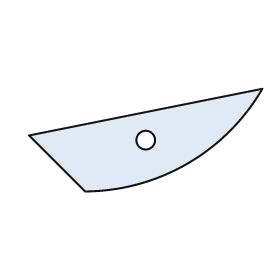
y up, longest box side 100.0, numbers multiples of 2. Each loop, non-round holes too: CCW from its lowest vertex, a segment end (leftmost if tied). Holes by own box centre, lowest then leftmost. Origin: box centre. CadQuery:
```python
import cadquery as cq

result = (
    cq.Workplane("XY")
    .moveTo(-26.0, -22.0)
    .threePointArc((18.0, -10.0), (50.0, 22.0))
    .lineTo(-50.0, 2.0)
    .close()
    .moveTo(0.0, 0.0)
    .circle(4.0)
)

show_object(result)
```